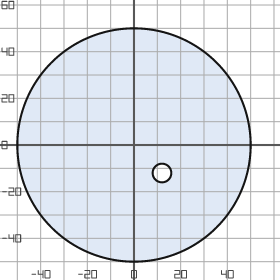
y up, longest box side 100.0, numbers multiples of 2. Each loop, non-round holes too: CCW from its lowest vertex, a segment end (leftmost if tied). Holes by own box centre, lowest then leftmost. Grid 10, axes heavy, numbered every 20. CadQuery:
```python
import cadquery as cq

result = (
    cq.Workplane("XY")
    .moveTo(0.0, 0.0)
    .circle(50.0)
    .moveTo(12.0, -12.0)
    .circle(4.0)
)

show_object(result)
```